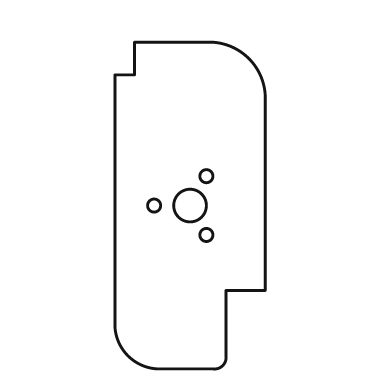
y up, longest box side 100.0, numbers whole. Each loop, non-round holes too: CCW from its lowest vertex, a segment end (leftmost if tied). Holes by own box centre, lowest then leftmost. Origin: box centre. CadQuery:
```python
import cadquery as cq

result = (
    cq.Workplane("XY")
    .moveTo(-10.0, -50.0)
    .lineTo(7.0, -50.0)
    .threePointArc((10.0, -49.0), (11.0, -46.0))
    .lineTo(11.0, -26.0)
    .lineTo(23.0, -26.0)
    .lineTo(23.0, 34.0)
    .threePointArc((18.0, 45.0), (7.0, 50.0))
    .lineTo(-17.0, 50.0)
    .lineTo(-17.0, 40.0)
    .lineTo(-23.0, 40.0)
    .lineTo(-23.0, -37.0)
    .threePointArc((-19.0, -46.0), (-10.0, -50.0))
    .close()
    .moveTo(5.0, -9.0)
    .circle(2.0)
    .moveTo(-11.0, 0.0)
    .circle(2.0)
    .moveTo(0.0, 0.0)
    .circle(5.0)
    .moveTo(5.0, 9.0)
    .circle(2.0)
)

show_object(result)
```